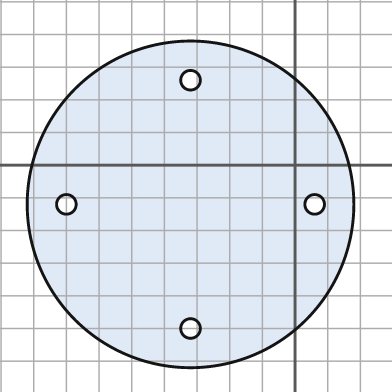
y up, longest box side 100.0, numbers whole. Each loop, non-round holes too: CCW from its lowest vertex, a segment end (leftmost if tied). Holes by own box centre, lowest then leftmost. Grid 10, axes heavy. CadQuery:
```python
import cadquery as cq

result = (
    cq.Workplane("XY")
    .moveTo(-32.0, -12.0)
    .circle(50.0)
    .moveTo(-32.0, -50.0)
    .circle(3.0)
    .moveTo(-70.0, -12.0)
    .circle(3.0)
    .moveTo(6.0, -12.0)
    .circle(3.0)
    .moveTo(-32.0, 26.0)
    .circle(3.0)
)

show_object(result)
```